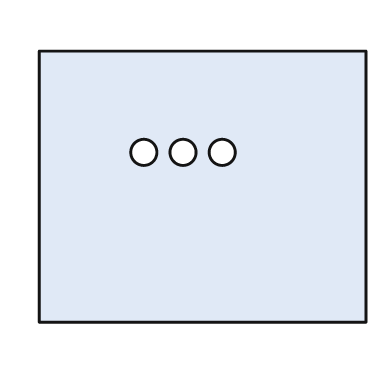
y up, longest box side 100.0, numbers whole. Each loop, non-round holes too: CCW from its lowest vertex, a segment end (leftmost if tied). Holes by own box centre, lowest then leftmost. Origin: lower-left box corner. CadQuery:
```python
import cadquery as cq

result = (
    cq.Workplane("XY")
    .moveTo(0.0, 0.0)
    .lineTo(100.0, 0.0)
    .lineTo(100.0, 83.0)
    .lineTo(0.0, 83.0)
    .close()
    .moveTo(32.0, 52.0)
    .circle(4.0)
    .moveTo(44.0, 52.0)
    .circle(4.0)
    .moveTo(56.0, 52.0)
    .circle(4.0)
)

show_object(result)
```